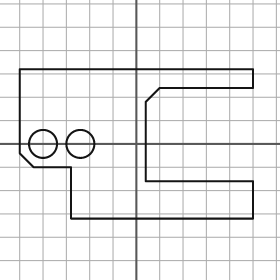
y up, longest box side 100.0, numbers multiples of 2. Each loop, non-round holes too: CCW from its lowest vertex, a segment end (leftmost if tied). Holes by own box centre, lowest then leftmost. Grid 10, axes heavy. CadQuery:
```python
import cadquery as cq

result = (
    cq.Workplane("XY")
    .moveTo(-28.0, -32.0)
    .lineTo(50.0, -32.0)
    .lineTo(50.0, -16.0)
    .lineTo(4.0, -16.0)
    .lineTo(4.0, 18.0)
    .lineTo(10.0, 24.0)
    .lineTo(50.0, 24.0)
    .lineTo(50.0, 32.0)
    .lineTo(-50.0, 32.0)
    .lineTo(-50.0, -4.0)
    .lineTo(-44.0, -10.0)
    .lineTo(-28.0, -10.0)
    .close()
    .moveTo(-40.0, 0.0)
    .circle(6.0)
    .moveTo(-24.0, 0.0)
    .circle(6.0)
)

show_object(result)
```